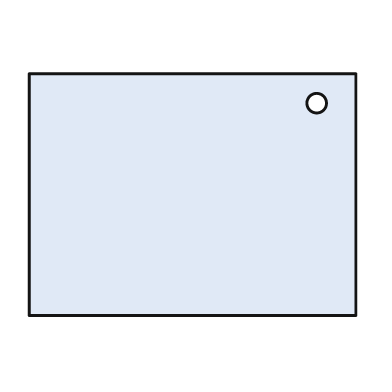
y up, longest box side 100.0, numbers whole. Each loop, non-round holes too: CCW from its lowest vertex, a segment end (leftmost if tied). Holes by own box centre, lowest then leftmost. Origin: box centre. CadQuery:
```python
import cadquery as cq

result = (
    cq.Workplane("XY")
    .moveTo(-50.0, -37.0)
    .lineTo(50.0, -37.0)
    .lineTo(50.0, 37.0)
    .lineTo(-50.0, 37.0)
    .close()
    .moveTo(38.0, 28.0)
    .circle(3.0)
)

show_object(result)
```